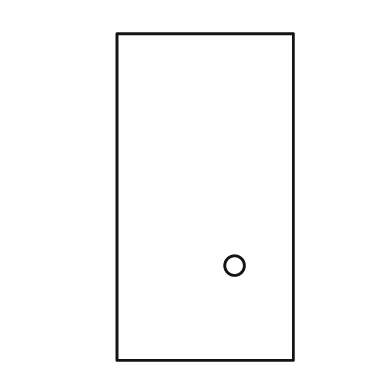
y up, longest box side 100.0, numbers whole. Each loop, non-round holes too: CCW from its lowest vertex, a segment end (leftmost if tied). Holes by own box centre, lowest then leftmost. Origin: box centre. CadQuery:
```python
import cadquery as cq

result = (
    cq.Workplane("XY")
    .moveTo(-27.0, -50.0)
    .lineTo(27.0, -50.0)
    .lineTo(27.0, 50.0)
    .lineTo(-27.0, 50.0)
    .close()
    .moveTo(9.0, -21.0)
    .circle(3.0)
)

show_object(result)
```